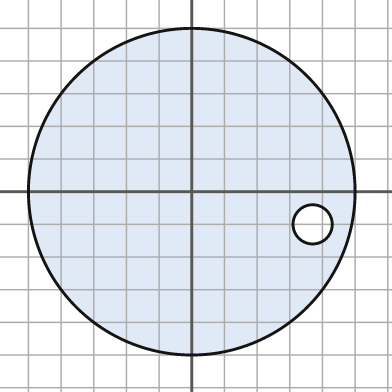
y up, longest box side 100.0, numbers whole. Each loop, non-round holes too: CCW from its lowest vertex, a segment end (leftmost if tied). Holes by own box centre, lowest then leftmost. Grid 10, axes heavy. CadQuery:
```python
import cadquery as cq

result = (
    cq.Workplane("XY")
    .moveTo(0.0, 0.0)
    .circle(50.0)
    .moveTo(37.0, -10.0)
    .circle(6.0)
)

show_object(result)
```